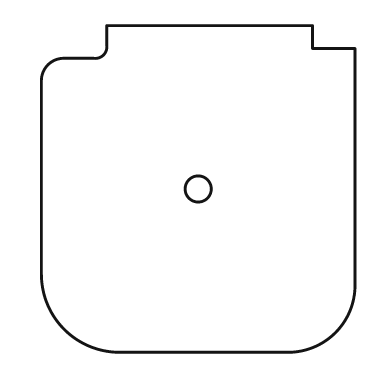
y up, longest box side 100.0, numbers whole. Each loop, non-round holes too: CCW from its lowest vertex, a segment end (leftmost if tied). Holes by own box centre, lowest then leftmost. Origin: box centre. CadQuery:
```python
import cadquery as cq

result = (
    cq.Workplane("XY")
    .moveTo(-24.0, -50.0)
    .lineTo(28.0, -50.0)
    .threePointArc((42.0, -44.0), (48.0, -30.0))
    .lineTo(48.0, 43.0)
    .lineTo(35.0, 43.0)
    .lineTo(35.0, 50.0)
    .lineTo(-28.0, 50.0)
    .lineTo(-28.0, 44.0)
    .threePointArc((-29.0, 41.0), (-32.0, 40.0))
    .lineTo(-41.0, 40.0)
    .threePointArc((-46.0, 38.0), (-48.0, 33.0))
    .lineTo(-48.0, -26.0)
    .threePointArc((-41.0, -43.0), (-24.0, -50.0))
    .close()
    .moveTo(0.0, 0.0)
    .circle(4.0)
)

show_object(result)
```